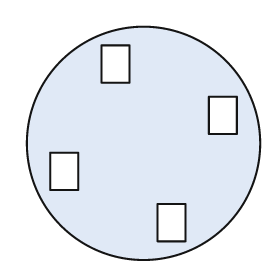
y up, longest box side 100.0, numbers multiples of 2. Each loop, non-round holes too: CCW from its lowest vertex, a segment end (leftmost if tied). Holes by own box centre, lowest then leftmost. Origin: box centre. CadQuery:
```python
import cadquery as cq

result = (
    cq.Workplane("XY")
    .moveTo(0.0, 0.0)
    .circle(50.0)
    .moveTo(6.0, -42.0)
    .lineTo(18.0, -42.0)
    .lineTo(18.0, -26.0)
    .lineTo(6.0, -26.0)
    .close()
    .moveTo(-40.0, -20.0)
    .lineTo(-28.0, -20.0)
    .lineTo(-28.0, -4.0)
    .lineTo(-40.0, -4.0)
    .close()
    .moveTo(28.0, 4.0)
    .lineTo(40.0, 4.0)
    .lineTo(40.0, 20.0)
    .lineTo(28.0, 20.0)
    .close()
    .moveTo(-18.0, 26.0)
    .lineTo(-6.0, 26.0)
    .lineTo(-6.0, 42.0)
    .lineTo(-18.0, 42.0)
    .close()
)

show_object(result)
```